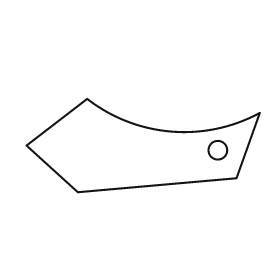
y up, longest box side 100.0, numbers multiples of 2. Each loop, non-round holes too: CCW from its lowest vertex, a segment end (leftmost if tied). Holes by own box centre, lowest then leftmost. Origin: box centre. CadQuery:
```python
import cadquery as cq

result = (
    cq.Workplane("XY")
    .moveTo(-28.0, -20.0)
    .lineTo(40.0, -14.0)
    .lineTo(50.0, 14.0)
    .threePointArc((12.0, 6.0), (-24.0, 20.0))
    .lineTo(-50.0, 0.0)
    .close()
    .moveTo(32.0, -2.0)
    .circle(4.0)
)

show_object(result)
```